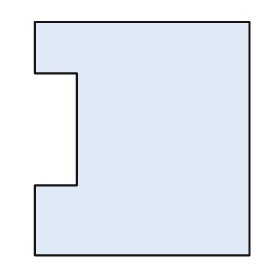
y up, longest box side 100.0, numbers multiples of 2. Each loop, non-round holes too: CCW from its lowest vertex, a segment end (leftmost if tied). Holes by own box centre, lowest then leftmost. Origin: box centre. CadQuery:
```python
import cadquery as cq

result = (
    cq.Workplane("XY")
    .moveTo(-46.0, -50.0)
    .lineTo(46.0, -50.0)
    .lineTo(46.0, 50.0)
    .lineTo(-46.0, 50.0)
    .lineTo(-46.0, 28.0)
    .lineTo(-28.0, 28.0)
    .lineTo(-28.0, -20.0)
    .lineTo(-46.0, -20.0)
    .close()
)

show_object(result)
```